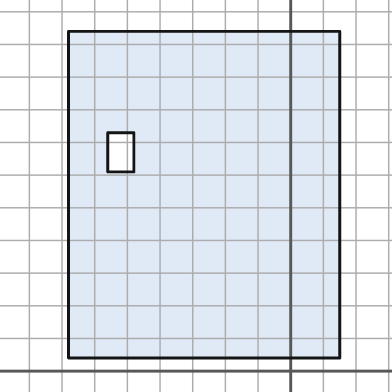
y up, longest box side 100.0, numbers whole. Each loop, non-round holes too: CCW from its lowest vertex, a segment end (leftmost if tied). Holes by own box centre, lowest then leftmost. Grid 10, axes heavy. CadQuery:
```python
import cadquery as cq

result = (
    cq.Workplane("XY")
    .moveTo(-68.0, 4.0)
    .lineTo(15.0, 4.0)
    .lineTo(15.0, 104.0)
    .lineTo(-68.0, 104.0)
    .close()
    .moveTo(-56.0, 61.0)
    .lineTo(-48.0, 61.0)
    .lineTo(-48.0, 73.0)
    .lineTo(-56.0, 73.0)
    .close()
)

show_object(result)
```